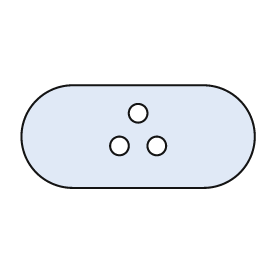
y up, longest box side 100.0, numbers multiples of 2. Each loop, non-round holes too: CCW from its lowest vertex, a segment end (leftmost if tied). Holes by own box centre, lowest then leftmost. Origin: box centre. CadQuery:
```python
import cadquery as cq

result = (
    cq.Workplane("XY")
    .moveTo(-28.0, -22.0)
    .lineTo(28.0, -22.0)
    .threePointArc((50.0, 0.0), (28.0, 22.0))
    .lineTo(-28.0, 22.0)
    .threePointArc((-50.0, 0.0), (-28.0, -22.0))
    .close()
    .moveTo(-8.0, -4.0)
    .circle(4.0)
    .moveTo(8.0, -4.0)
    .circle(4.0)
    .moveTo(0.0, 10.0)
    .circle(4.0)
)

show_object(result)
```